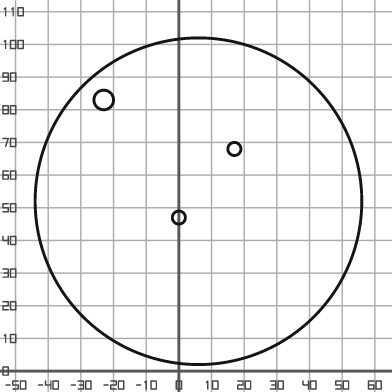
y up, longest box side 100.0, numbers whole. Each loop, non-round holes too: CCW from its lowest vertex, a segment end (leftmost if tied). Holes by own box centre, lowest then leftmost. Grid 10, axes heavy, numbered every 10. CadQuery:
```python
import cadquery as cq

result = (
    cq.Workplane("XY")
    .moveTo(6.0, 52.0)
    .circle(50.0)
    .moveTo(0.0, 47.0)
    .circle(2.0)
    .moveTo(17.0, 68.0)
    .circle(2.0)
    .moveTo(-23.0, 83.0)
    .circle(3.0)
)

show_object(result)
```